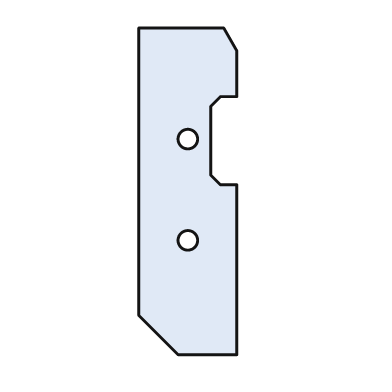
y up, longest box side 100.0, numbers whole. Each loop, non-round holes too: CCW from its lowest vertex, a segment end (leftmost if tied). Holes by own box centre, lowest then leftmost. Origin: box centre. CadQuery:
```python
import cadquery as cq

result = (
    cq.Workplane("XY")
    .moveTo(-3.0, -50.0)
    .lineTo(15.0, -50.0)
    .lineTo(15.0, 2.0)
    .lineTo(10.0, 2.0)
    .lineTo(7.0, 5.0)
    .lineTo(7.0, 26.0)
    .lineTo(10.0, 29.0)
    .lineTo(15.0, 29.0)
    .lineTo(15.0, 43.0)
    .lineTo(11.0, 50.0)
    .lineTo(-15.0, 50.0)
    .lineTo(-15.0, -38.0)
    .close()
    .moveTo(0.0, -15.0)
    .circle(3.0)
    .moveTo(0.0, 16.0)
    .circle(3.0)
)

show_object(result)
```